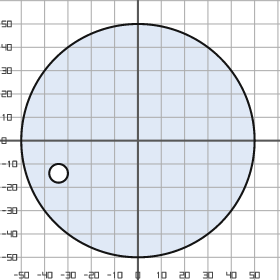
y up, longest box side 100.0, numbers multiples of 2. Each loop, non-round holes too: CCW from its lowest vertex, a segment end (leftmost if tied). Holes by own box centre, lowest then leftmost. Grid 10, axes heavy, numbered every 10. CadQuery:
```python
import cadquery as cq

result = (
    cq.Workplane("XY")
    .moveTo(0.0, 0.0)
    .circle(50.0)
    .moveTo(-34.0, -14.0)
    .circle(4.0)
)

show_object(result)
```